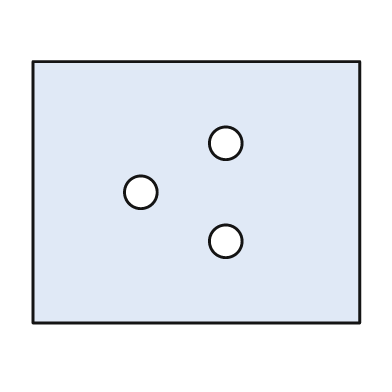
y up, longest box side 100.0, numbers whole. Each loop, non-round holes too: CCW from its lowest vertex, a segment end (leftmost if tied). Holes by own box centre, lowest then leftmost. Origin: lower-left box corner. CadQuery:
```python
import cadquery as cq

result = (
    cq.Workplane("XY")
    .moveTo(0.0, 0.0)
    .lineTo(100.0, 0.0)
    .lineTo(100.0, 80.0)
    .lineTo(0.0, 80.0)
    .close()
    .moveTo(59.0, 25.0)
    .circle(5.0)
    .moveTo(33.0, 40.0)
    .circle(5.0)
    .moveTo(59.0, 55.0)
    .circle(5.0)
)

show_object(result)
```